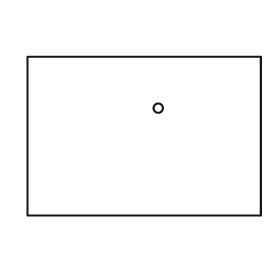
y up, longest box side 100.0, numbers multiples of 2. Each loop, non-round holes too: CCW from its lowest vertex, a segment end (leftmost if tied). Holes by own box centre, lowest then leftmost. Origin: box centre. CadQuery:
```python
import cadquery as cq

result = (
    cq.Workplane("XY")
    .moveTo(-50.0, -34.0)
    .lineTo(50.0, -34.0)
    .lineTo(50.0, 34.0)
    .lineTo(-50.0, 34.0)
    .close()
    .moveTo(6.0, 12.0)
    .circle(2.0)
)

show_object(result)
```